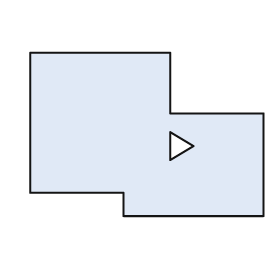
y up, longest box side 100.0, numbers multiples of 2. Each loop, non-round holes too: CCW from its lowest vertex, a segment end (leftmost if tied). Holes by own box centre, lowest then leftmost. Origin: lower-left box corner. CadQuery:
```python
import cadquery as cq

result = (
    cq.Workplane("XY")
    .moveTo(40.0, 0.0)
    .lineTo(100.0, 0.0)
    .lineTo(100.0, 44.0)
    .lineTo(60.0, 44.0)
    .lineTo(60.0, 70.0)
    .lineTo(0.0, 70.0)
    .lineTo(0.0, 10.0)
    .lineTo(40.0, 10.0)
    .close()
    .moveTo(60.0, 24.0)
    .lineTo(70.0, 30.0)
    .lineTo(60.0, 36.0)
    .close()
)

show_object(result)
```